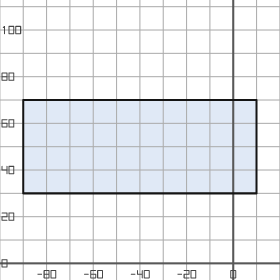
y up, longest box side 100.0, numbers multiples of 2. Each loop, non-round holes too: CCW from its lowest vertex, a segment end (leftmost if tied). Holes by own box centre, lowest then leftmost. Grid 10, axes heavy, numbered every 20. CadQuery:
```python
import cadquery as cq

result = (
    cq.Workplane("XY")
    .moveTo(-90.0, 30.0)
    .lineTo(10.0, 30.0)
    .lineTo(10.0, 70.0)
    .lineTo(-90.0, 70.0)
    .close()
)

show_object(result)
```